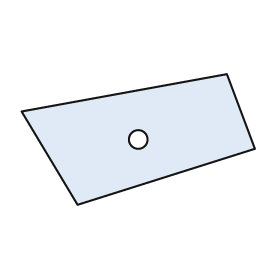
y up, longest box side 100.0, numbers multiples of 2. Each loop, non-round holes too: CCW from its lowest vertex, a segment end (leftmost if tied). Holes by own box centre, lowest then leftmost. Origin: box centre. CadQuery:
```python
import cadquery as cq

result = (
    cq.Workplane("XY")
    .moveTo(-26.0, -28.0)
    .lineTo(50.0, -4.0)
    .lineTo(38.0, 28.0)
    .lineTo(-50.0, 12.0)
    .close()
    .moveTo(0.0, 0.0)
    .circle(4.0)
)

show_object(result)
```